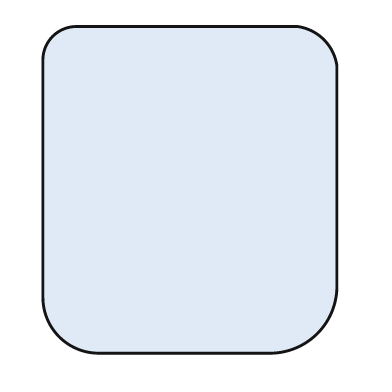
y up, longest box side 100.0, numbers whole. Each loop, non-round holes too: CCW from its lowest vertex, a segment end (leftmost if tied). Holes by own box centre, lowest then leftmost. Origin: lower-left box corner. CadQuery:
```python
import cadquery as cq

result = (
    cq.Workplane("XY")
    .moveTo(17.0, 0.0)
    .lineTo(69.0, 0.0)
    .threePointArc((84.0, 6.0), (90.0, 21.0))
    .lineTo(90.0, 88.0)
    .threePointArc((86.0, 96.0), (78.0, 100.0))
    .lineTo(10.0, 100.0)
    .threePointArc((3.0, 97.0), (0.0, 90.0))
    .lineTo(0.0, 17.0)
    .threePointArc((5.0, 5.0), (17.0, 0.0))
    .close()
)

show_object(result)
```